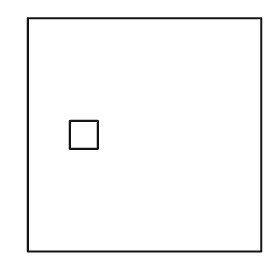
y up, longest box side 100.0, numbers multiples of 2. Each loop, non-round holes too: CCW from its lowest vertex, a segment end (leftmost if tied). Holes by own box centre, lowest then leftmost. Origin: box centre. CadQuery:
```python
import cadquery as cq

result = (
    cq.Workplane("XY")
    .moveTo(-50.0, -50.0)
    .lineTo(50.0, -50.0)
    .lineTo(50.0, 50.0)
    .lineTo(-50.0, 50.0)
    .close()
    .moveTo(-32.0, -6.0)
    .lineTo(-20.0, -6.0)
    .lineTo(-20.0, 6.0)
    .lineTo(-32.0, 6.0)
    .close()
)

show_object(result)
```